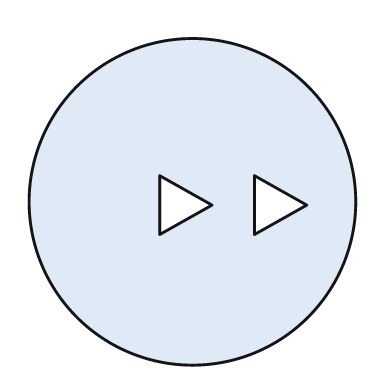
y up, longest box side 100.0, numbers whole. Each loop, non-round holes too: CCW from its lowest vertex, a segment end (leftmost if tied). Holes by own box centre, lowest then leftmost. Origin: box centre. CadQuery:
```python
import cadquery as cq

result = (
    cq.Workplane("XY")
    .moveTo(0.0, 0.0)
    .circle(50.0)
    .moveTo(-10.0, -10.0)
    .lineTo(6.0, -1.0)
    .lineTo(-10.0, 8.0)
    .close()
    .moveTo(19.0, -10.0)
    .lineTo(35.0, -1.0)
    .lineTo(19.0, 8.0)
    .close()
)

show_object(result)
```